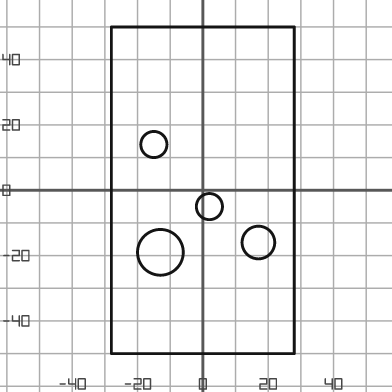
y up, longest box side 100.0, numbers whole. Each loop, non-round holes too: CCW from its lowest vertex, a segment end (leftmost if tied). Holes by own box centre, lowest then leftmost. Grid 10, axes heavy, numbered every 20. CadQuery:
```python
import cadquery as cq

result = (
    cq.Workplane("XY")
    .moveTo(-28.0, -50.0)
    .lineTo(28.0, -50.0)
    .lineTo(28.0, 50.0)
    .lineTo(-28.0, 50.0)
    .close()
    .moveTo(-13.0, -19.0)
    .circle(7.0)
    .moveTo(17.0, -16.0)
    .circle(5.0)
    .moveTo(2.0, -5.0)
    .circle(4.0)
    .moveTo(-15.0, 14.0)
    .circle(4.0)
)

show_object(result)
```